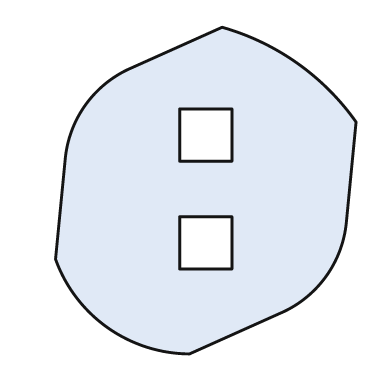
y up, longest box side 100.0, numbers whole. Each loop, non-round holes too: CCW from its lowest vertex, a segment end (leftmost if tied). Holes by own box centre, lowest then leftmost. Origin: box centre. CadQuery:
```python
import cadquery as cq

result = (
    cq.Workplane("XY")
    .moveTo(-5.0, -50.0)
    .lineTo(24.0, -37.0)
    .threePointArc((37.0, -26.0), (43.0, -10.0))
    .lineTo(46.0, 21.0)
    .threePointArc((28.0, 39.0), (5.0, 50.0))
    .lineTo(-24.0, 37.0)
    .threePointArc((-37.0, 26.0), (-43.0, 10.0))
    .lineTo(-46.0, -21.0)
    .threePointArc((-30.0, -42.0), (-5.0, -50.0))
    .close()
    .moveTo(-8.0, -24.0)
    .lineTo(8.0, -24.0)
    .lineTo(8.0, -8.0)
    .lineTo(-8.0, -8.0)
    .close()
    .moveTo(-8.0, 9.0)
    .lineTo(8.0, 9.0)
    .lineTo(8.0, 25.0)
    .lineTo(-8.0, 25.0)
    .close()
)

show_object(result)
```